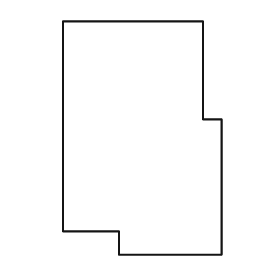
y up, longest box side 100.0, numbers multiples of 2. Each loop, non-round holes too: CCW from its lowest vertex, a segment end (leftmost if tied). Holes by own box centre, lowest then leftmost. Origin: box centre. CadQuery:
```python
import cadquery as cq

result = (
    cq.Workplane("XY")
    .moveTo(-10.0, -50.0)
    .lineTo(34.0, -50.0)
    .lineTo(34.0, 8.0)
    .lineTo(26.0, 8.0)
    .lineTo(26.0, 50.0)
    .lineTo(-34.0, 50.0)
    .lineTo(-34.0, -40.0)
    .lineTo(-10.0, -40.0)
    .close()
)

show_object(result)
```